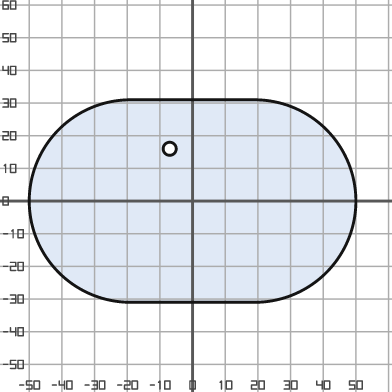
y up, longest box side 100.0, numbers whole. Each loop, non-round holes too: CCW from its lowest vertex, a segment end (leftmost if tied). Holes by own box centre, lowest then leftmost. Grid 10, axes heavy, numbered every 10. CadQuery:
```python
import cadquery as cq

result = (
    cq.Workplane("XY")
    .moveTo(-19.0, -31.0)
    .lineTo(19.0, -31.0)
    .threePointArc((50.0, 0.0), (19.0, 31.0))
    .lineTo(-19.0, 31.0)
    .threePointArc((-50.0, 0.0), (-19.0, -31.0))
    .close()
    .moveTo(-7.0, 16.0)
    .circle(2.0)
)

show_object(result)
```